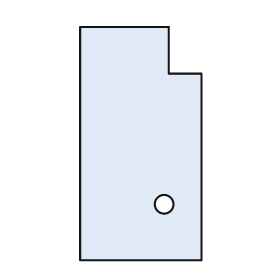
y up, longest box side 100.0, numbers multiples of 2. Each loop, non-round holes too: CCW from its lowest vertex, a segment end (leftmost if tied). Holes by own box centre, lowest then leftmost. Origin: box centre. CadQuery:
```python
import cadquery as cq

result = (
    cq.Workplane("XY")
    .moveTo(-26.0, -50.0)
    .lineTo(26.0, -50.0)
    .lineTo(26.0, 30.0)
    .lineTo(12.0, 30.0)
    .lineTo(12.0, 50.0)
    .lineTo(-26.0, 50.0)
    .close()
    .moveTo(10.0, -26.0)
    .circle(4.0)
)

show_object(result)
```